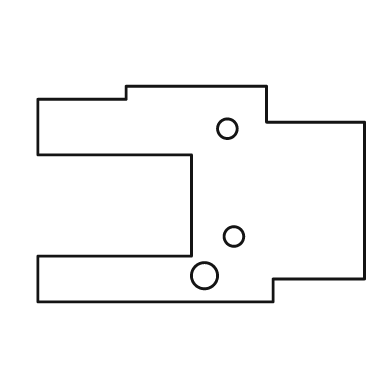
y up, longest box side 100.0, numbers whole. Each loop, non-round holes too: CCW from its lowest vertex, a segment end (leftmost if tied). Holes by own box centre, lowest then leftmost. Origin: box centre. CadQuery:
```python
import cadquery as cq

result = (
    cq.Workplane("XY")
    .moveTo(-50.0, -33.0)
    .lineTo(22.0, -33.0)
    .lineTo(22.0, -26.0)
    .lineTo(50.0, -26.0)
    .lineTo(50.0, 22.0)
    .lineTo(20.0, 22.0)
    .lineTo(20.0, 33.0)
    .lineTo(-23.0, 33.0)
    .lineTo(-23.0, 29.0)
    .lineTo(-50.0, 29.0)
    .lineTo(-50.0, 12.0)
    .lineTo(-3.0, 12.0)
    .lineTo(-3.0, -19.0)
    .lineTo(-50.0, -19.0)
    .close()
    .moveTo(1.0, -25.0)
    .circle(4.0)
    .moveTo(10.0, -13.0)
    .circle(3.0)
    .moveTo(8.0, 20.0)
    .circle(3.0)
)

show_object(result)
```